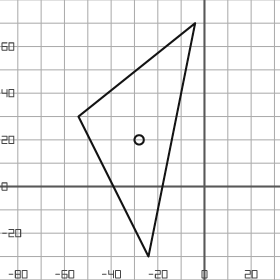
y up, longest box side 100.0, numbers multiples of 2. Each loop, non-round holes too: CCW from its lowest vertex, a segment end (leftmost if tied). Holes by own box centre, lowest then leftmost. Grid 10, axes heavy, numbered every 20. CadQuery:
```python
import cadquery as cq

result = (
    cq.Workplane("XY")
    .moveTo(-24.0, -30.0)
    .lineTo(-4.0, 70.0)
    .lineTo(-54.0, 30.0)
    .close()
    .moveTo(-28.0, 20.0)
    .circle(2.0)
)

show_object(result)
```